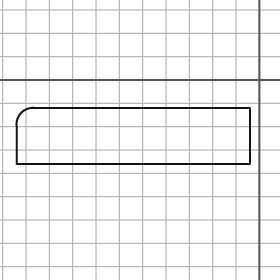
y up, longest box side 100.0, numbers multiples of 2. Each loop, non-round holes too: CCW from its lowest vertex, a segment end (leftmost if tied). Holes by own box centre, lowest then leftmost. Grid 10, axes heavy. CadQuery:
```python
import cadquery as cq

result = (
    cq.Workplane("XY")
    .moveTo(-104.0, -36.0)
    .lineTo(-4.0, -36.0)
    .lineTo(-4.0, -12.0)
    .lineTo(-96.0, -12.0)
    .threePointArc((-102.0, -14.0), (-104.0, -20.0))
    .close()
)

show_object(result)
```